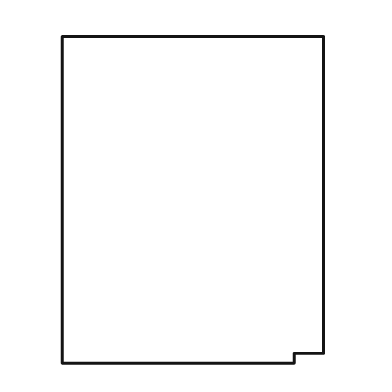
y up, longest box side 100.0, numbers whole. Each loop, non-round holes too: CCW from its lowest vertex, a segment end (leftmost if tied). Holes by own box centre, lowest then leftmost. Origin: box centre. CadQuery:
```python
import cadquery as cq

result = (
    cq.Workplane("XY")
    .moveTo(-40.0, -50.0)
    .lineTo(31.0, -50.0)
    .lineTo(31.0, -47.0)
    .lineTo(40.0, -47.0)
    .lineTo(40.0, 50.0)
    .lineTo(-40.0, 50.0)
    .close()
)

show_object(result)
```